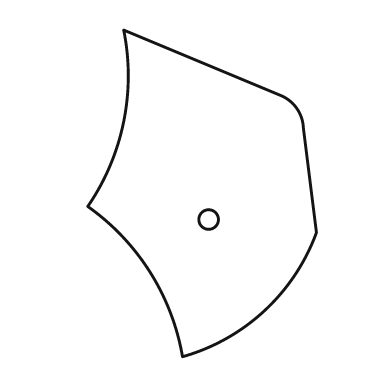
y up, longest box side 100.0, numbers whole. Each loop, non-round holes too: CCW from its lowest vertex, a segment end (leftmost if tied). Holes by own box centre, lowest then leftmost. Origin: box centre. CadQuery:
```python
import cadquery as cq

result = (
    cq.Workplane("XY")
    .moveTo(-6.0, -50.0)
    .threePointArc((19.0, -36.0), (35.0, -12.0))
    .lineTo(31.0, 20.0)
    .threePointArc((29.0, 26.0), (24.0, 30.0))
    .lineTo(-24.0, 50.0)
    .threePointArc((-24.0, 22.0), (-35.0, -4.0))
    .threePointArc((-16.0, -24.0), (-6.0, -50.0))
    .close()
    .moveTo(2.0, -8.0)
    .circle(3.0)
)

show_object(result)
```